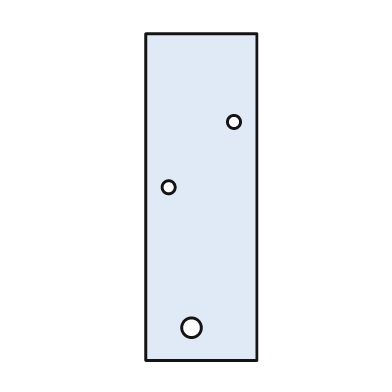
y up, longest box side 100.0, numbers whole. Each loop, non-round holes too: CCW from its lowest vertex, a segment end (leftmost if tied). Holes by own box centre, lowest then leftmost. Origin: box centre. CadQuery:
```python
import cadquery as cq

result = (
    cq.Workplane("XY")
    .moveTo(-17.0, -50.0)
    .lineTo(17.0, -50.0)
    .lineTo(17.0, 50.0)
    .lineTo(-17.0, 50.0)
    .close()
    .moveTo(-3.0, -40.0)
    .circle(3.0)
    .moveTo(-10.0, 3.0)
    .circle(2.0)
    .moveTo(10.0, 23.0)
    .circle(2.0)
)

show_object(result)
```